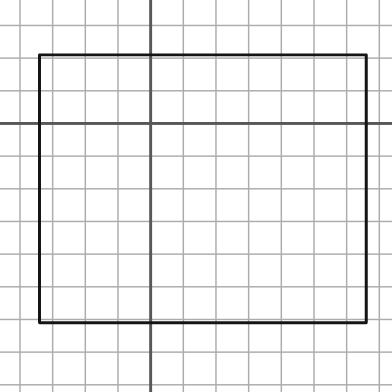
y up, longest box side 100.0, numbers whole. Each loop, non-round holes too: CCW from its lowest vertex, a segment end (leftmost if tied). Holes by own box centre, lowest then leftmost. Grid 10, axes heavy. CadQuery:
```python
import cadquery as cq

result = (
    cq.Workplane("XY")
    .moveTo(-34.0, -61.0)
    .lineTo(66.0, -61.0)
    .lineTo(66.0, 21.0)
    .lineTo(-34.0, 21.0)
    .close()
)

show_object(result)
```